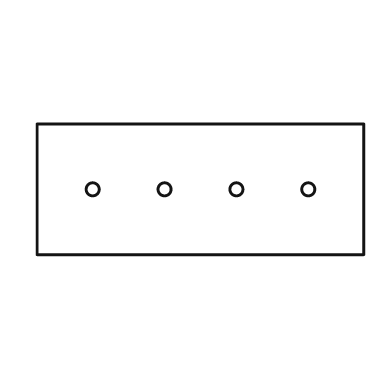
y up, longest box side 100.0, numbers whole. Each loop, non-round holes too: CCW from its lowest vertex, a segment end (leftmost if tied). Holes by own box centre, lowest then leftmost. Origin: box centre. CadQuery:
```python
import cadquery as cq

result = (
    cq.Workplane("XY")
    .moveTo(-50.0, -20.0)
    .lineTo(50.0, -20.0)
    .lineTo(50.0, 20.0)
    .lineTo(-50.0, 20.0)
    .close()
    .moveTo(-33.0, 0.0)
    .circle(2.0)
    .moveTo(-11.0, 0.0)
    .circle(2.0)
    .moveTo(11.0, 0.0)
    .circle(2.0)
    .moveTo(33.0, 0.0)
    .circle(2.0)
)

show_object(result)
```